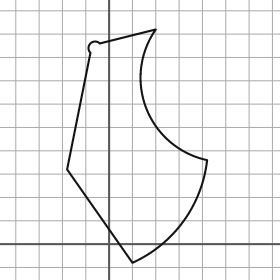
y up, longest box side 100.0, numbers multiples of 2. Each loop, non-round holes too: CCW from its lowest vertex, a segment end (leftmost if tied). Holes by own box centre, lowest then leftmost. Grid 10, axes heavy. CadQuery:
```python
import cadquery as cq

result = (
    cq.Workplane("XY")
    .moveTo(10.0, -8.0)
    .threePointArc((32.0, 10.0), (42.0, 36.0))
    .threePointArc((16.0, 58.0), (20.0, 92.0))
    .lineTo(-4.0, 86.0)
    .threePointArc((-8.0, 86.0), (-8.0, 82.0))
    .lineTo(-18.0, 32.0)
    .close()
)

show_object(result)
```